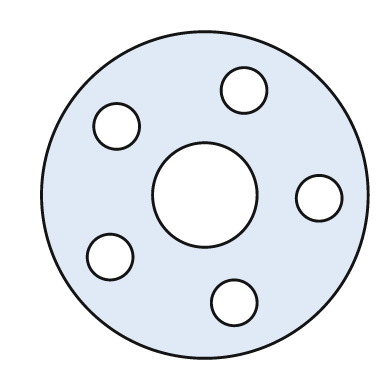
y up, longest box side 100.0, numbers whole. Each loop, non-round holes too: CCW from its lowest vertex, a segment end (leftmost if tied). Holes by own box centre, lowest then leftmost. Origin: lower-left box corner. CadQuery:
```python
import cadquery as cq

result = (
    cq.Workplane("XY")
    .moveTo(50.0, 50.0)
    .circle(50.0)
    .moveTo(59.0, 17.0)
    .circle(7.0)
    .moveTo(21.0, 31.0)
    .circle(7.0)
    .moveTo(85.0, 49.0)
    .circle(7.0)
    .moveTo(50.0, 50.0)
    .circle(16.0)
    .moveTo(23.0, 71.0)
    .circle(7.0)
    .moveTo(62.0, 82.0)
    .circle(7.0)
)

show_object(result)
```